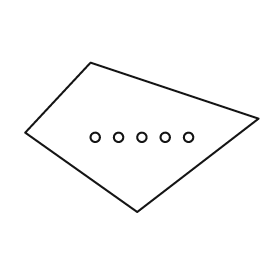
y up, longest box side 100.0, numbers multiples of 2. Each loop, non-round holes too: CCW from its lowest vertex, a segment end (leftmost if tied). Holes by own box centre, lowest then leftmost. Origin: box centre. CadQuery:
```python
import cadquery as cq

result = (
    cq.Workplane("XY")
    .moveTo(-2.0, -32.0)
    .lineTo(50.0, 8.0)
    .lineTo(-22.0, 32.0)
    .lineTo(-50.0, 2.0)
    .close()
    .moveTo(-20.0, 0.0)
    .circle(2.0)
    .moveTo(-10.0, 0.0)
    .circle(2.0)
    .moveTo(0.0, 0.0)
    .circle(2.0)
    .moveTo(10.0, 0.0)
    .circle(2.0)
    .moveTo(20.0, 0.0)
    .circle(2.0)
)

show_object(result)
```